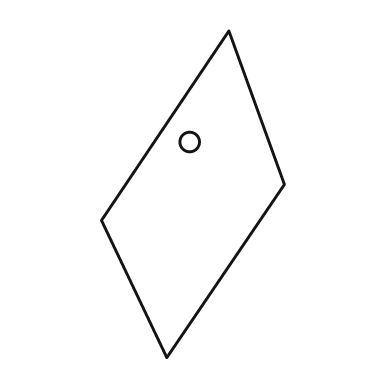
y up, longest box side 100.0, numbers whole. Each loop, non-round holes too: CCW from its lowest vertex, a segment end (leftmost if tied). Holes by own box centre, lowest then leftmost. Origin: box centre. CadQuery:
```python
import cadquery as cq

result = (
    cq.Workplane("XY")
    .moveTo(-8.0, -50.0)
    .lineTo(28.0, 3.0)
    .lineTo(11.0, 50.0)
    .lineTo(-28.0, -8.0)
    .close()
    .moveTo(-1.0, 16.0)
    .circle(3.0)
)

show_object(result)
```